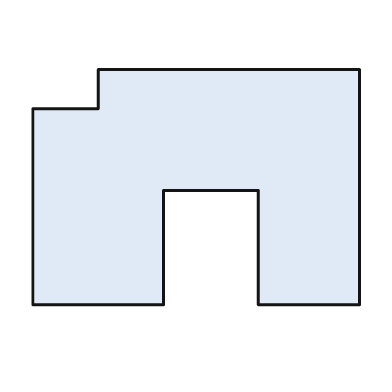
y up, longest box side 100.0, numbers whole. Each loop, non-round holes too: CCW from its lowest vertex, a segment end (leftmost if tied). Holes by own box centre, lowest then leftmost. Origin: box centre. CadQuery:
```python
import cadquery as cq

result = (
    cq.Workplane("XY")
    .moveTo(-50.0, -36.0)
    .lineTo(-10.0, -36.0)
    .lineTo(-10.0, -1.0)
    .lineTo(19.0, -1.0)
    .lineTo(19.0, -36.0)
    .lineTo(50.0, -36.0)
    .lineTo(50.0, 36.0)
    .lineTo(-30.0, 36.0)
    .lineTo(-30.0, 24.0)
    .lineTo(-50.0, 24.0)
    .close()
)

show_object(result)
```